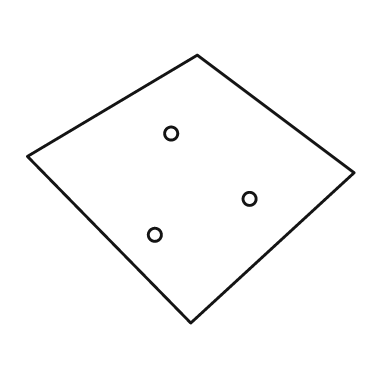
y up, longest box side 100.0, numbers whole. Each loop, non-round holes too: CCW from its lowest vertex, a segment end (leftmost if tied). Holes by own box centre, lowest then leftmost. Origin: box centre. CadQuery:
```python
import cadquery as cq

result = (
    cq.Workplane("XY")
    .moveTo(0.0, -41.0)
    .lineTo(50.0, 5.0)
    .lineTo(2.0, 41.0)
    .lineTo(-50.0, 10.0)
    .close()
    .moveTo(-11.0, -14.0)
    .circle(2.0)
    .moveTo(18.0, -3.0)
    .circle(2.0)
    .moveTo(-6.0, 17.0)
    .circle(2.0)
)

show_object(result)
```